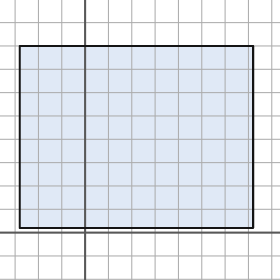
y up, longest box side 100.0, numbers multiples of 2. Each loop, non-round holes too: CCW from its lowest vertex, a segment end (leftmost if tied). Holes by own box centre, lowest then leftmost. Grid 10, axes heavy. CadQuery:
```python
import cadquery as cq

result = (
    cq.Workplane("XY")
    .moveTo(-28.0, 2.0)
    .lineTo(72.0, 2.0)
    .lineTo(72.0, 80.0)
    .lineTo(-28.0, 80.0)
    .close()
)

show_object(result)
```